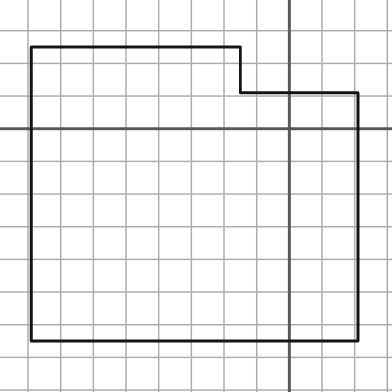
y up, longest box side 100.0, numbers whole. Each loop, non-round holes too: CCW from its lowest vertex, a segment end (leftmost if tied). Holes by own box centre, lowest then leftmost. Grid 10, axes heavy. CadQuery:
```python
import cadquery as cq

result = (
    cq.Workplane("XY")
    .moveTo(-79.0, -65.0)
    .lineTo(21.0, -65.0)
    .lineTo(21.0, 11.0)
    .lineTo(-15.0, 11.0)
    .lineTo(-15.0, 25.0)
    .lineTo(-79.0, 25.0)
    .close()
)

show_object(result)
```